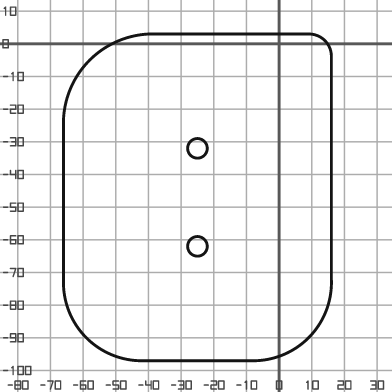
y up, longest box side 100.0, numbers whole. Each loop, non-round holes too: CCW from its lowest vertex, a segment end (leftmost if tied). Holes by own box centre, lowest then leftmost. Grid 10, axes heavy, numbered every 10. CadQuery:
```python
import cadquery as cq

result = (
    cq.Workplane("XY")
    .moveTo(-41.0, -97.0)
    .lineTo(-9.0, -97.0)
    .threePointArc((9.0, -90.0), (16.0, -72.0))
    .lineTo(16.0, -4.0)
    .threePointArc((14.0, 1.0), (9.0, 3.0))
    .lineTo(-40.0, 3.0)
    .threePointArc((-58.0, -5.0), (-66.0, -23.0))
    .lineTo(-66.0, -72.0)
    .threePointArc((-59.0, -90.0), (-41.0, -97.0))
    .close()
    .moveTo(-25.0, -62.0)
    .circle(3.0)
    .moveTo(-25.0, -32.0)
    .circle(3.0)
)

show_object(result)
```